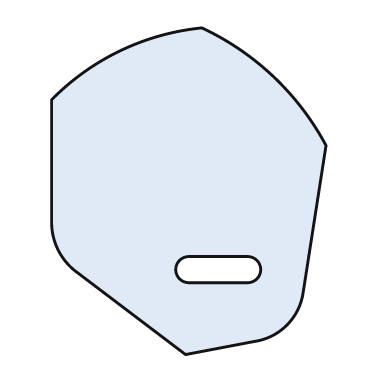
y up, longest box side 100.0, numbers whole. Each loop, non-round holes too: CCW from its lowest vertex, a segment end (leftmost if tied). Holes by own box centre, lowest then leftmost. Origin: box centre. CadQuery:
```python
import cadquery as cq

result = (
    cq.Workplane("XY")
    .moveTo(-1.0, -50.0)
    .lineTo(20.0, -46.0)
    .threePointArc((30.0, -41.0), (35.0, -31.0))
    .lineTo(42.0, 14.0)
    .threePointArc((26.0, 35.0), (4.0, 50.0))
    .threePointArc((-21.0, 43.0), (-42.0, 28.0))
    .lineTo(-42.0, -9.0)
    .threePointArc((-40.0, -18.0), (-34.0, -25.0))
    .close()
    .moveTo(0.0, -28.0)
    .lineTo(18.0, -28.0)
    .threePointArc((22.0, -24.0), (18.0, -20.0))
    .lineTo(0.0, -20.0)
    .threePointArc((-4.0, -24.0), (0.0, -28.0))
    .close()
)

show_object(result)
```